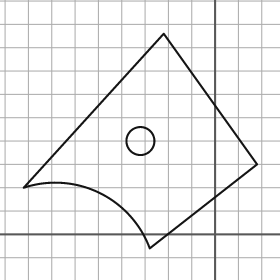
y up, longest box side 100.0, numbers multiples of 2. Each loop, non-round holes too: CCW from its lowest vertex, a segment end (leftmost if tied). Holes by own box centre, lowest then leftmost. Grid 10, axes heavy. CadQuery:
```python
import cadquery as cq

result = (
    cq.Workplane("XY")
    .moveTo(-28.0, -6.0)
    .lineTo(18.0, 30.0)
    .lineTo(-22.0, 86.0)
    .lineTo(-82.0, 20.0)
    .threePointArc((-50.0, 18.0), (-28.0, -6.0))
    .close()
    .moveTo(-32.0, 40.0)
    .circle(6.0)
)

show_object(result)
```